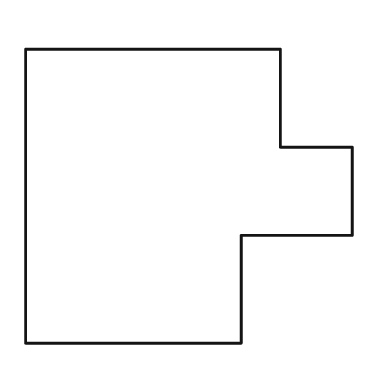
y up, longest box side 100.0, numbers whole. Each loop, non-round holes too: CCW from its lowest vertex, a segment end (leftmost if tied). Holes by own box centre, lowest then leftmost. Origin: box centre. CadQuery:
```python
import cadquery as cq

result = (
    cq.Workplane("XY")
    .moveTo(-50.0, -45.0)
    .lineTo(16.0, -45.0)
    .lineTo(16.0, -12.0)
    .lineTo(50.0, -12.0)
    .lineTo(50.0, 15.0)
    .lineTo(28.0, 15.0)
    .lineTo(28.0, 45.0)
    .lineTo(-50.0, 45.0)
    .close()
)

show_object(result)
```